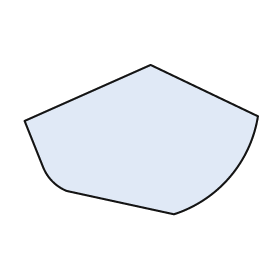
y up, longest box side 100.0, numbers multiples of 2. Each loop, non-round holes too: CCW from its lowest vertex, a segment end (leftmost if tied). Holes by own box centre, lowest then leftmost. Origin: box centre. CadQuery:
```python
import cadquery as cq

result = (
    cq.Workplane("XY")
    .moveTo(14.0, -32.0)
    .threePointArc((38.0, -16.0), (50.0, 10.0))
    .lineTo(4.0, 32.0)
    .lineTo(-50.0, 8.0)
    .lineTo(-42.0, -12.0)
    .threePointArc((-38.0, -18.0), (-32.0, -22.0))
    .close()
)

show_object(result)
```